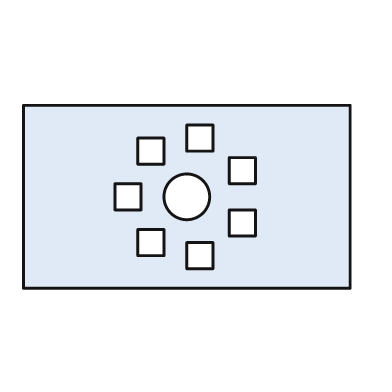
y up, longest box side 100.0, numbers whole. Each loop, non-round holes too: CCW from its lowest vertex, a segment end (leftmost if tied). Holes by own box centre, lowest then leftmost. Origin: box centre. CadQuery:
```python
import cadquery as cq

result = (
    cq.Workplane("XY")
    .moveTo(-50.0, -28.0)
    .lineTo(50.0, -28.0)
    .lineTo(50.0, 28.0)
    .lineTo(-50.0, 28.0)
    .close()
    .moveTo(0.0, -22.0)
    .lineTo(8.0, -22.0)
    .lineTo(8.0, -14.0)
    .lineTo(0.0, -14.0)
    .close()
    .moveTo(-15.0, -18.0)
    .lineTo(-7.0, -18.0)
    .lineTo(-7.0, -10.0)
    .lineTo(-15.0, -10.0)
    .close()
    .moveTo(13.0, -12.0)
    .lineTo(21.0, -12.0)
    .lineTo(21.0, -4.0)
    .lineTo(13.0, -4.0)
    .close()
    .moveTo(-22.0, -4.0)
    .lineTo(-14.0, -4.0)
    .lineTo(-14.0, 4.0)
    .lineTo(-22.0, 4.0)
    .close()
    .moveTo(0.0, 0.0)
    .circle(7.0)
    .moveTo(13.0, 4.0)
    .lineTo(21.0, 4.0)
    .lineTo(21.0, 12.0)
    .lineTo(13.0, 12.0)
    .close()
    .moveTo(-15.0, 10.0)
    .lineTo(-7.0, 10.0)
    .lineTo(-7.0, 18.0)
    .lineTo(-15.0, 18.0)
    .close()
    .moveTo(0.0, 14.0)
    .lineTo(8.0, 14.0)
    .lineTo(8.0, 22.0)
    .lineTo(0.0, 22.0)
    .close()
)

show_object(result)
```